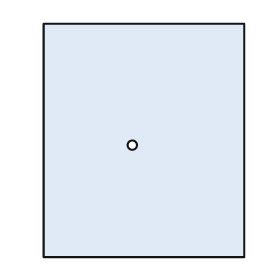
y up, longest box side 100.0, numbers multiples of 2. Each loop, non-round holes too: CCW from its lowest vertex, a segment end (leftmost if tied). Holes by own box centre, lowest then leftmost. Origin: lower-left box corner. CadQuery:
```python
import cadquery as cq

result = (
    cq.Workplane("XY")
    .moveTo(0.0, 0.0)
    .lineTo(86.0, 0.0)
    .lineTo(86.0, 100.0)
    .lineTo(0.0, 100.0)
    .close()
    .moveTo(38.0, 48.0)
    .circle(2.0)
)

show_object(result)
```